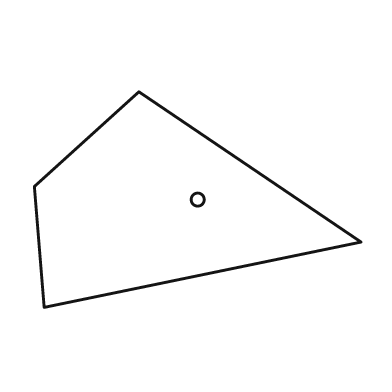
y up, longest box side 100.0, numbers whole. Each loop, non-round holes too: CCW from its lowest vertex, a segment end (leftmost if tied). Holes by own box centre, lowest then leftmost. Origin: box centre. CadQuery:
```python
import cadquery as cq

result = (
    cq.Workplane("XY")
    .moveTo(-47.0, -33.0)
    .lineTo(50.0, -13.0)
    .lineTo(-18.0, 33.0)
    .lineTo(-50.0, 4.0)
    .close()
    .moveTo(0.0, 0.0)
    .circle(2.0)
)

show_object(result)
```